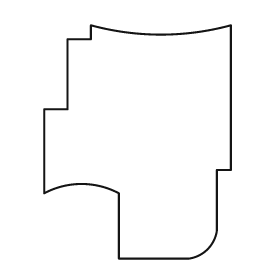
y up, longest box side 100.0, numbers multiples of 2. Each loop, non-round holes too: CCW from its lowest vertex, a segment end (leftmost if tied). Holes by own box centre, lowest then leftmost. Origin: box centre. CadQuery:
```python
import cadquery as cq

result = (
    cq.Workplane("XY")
    .moveTo(-8.0, -50.0)
    .lineTo(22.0, -50.0)
    .threePointArc((30.0, -46.0), (34.0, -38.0))
    .lineTo(34.0, -12.0)
    .lineTo(40.0, -12.0)
    .lineTo(40.0, 50.0)
    .threePointArc((10.0, 46.0), (-20.0, 50.0))
    .lineTo(-20.0, 44.0)
    .lineTo(-30.0, 44.0)
    .lineTo(-30.0, 14.0)
    .lineTo(-40.0, 14.0)
    .lineTo(-40.0, -22.0)
    .threePointArc((-24.0, -18.0), (-8.0, -22.0))
    .close()
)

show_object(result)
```